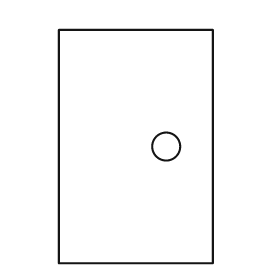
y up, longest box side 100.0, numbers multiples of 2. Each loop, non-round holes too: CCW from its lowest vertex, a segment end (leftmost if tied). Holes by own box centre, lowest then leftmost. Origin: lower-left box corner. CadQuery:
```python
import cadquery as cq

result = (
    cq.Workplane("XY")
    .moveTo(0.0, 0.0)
    .lineTo(66.0, 0.0)
    .lineTo(66.0, 100.0)
    .lineTo(0.0, 100.0)
    .close()
    .moveTo(46.0, 50.0)
    .circle(6.0)
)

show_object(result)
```